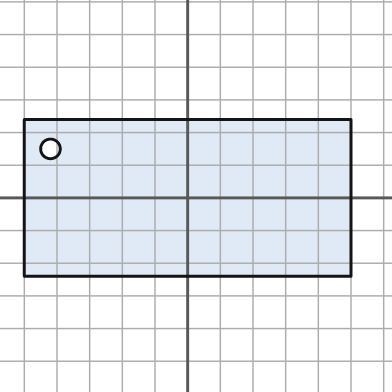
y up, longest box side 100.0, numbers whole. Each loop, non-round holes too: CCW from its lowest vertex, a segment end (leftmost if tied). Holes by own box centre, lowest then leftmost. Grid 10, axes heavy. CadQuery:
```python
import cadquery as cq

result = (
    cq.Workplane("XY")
    .moveTo(-50.0, -24.0)
    .lineTo(50.0, -24.0)
    .lineTo(50.0, 24.0)
    .lineTo(-50.0, 24.0)
    .close()
    .moveTo(-42.0, 15.0)
    .circle(3.0)
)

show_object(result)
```